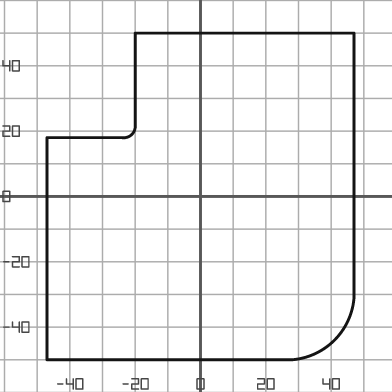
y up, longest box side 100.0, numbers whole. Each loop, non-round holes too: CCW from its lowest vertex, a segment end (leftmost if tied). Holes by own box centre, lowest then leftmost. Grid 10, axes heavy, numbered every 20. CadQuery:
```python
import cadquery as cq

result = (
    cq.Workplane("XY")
    .moveTo(-47.0, -50.0)
    .lineTo(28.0, -50.0)
    .threePointArc((41.0, -44.0), (47.0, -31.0))
    .lineTo(47.0, 50.0)
    .lineTo(-20.0, 50.0)
    .lineTo(-20.0, 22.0)
    .threePointArc((-21.0, 19.0), (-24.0, 18.0))
    .lineTo(-47.0, 18.0)
    .close()
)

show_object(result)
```